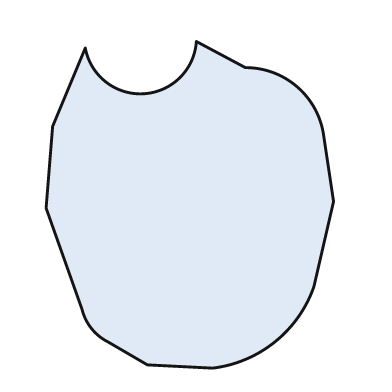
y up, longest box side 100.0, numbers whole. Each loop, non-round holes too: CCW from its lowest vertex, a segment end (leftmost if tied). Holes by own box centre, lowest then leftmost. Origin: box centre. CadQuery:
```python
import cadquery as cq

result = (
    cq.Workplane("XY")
    .moveTo(7.0, -50.0)
    .threePointArc((26.0, -42.0), (38.0, -25.0))
    .lineTo(44.0, 1.0)
    .lineTo(41.0, 21.0)
    .threePointArc((33.0, 36.0), (17.0, 42.0))
    .lineTo(2.0, 50.0)
    .threePointArc((-14.0, 34.0), (-32.0, 48.0))
    .lineTo(-42.0, 24.0)
    .lineTo(-44.0, -1.0)
    .lineTo(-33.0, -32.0)
    .threePointArc((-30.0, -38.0), (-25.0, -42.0))
    .lineTo(-13.0, -49.0)
    .close()
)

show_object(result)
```